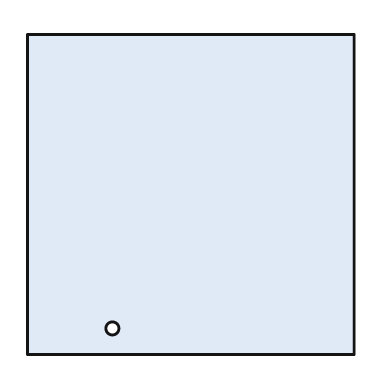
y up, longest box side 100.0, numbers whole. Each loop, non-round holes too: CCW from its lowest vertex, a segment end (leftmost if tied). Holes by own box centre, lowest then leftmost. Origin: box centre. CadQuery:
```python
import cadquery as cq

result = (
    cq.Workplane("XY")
    .moveTo(-50.0, -49.0)
    .lineTo(50.0, -49.0)
    .lineTo(50.0, 49.0)
    .lineTo(-50.0, 49.0)
    .close()
    .moveTo(-24.0, -41.0)
    .circle(2.0)
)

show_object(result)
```